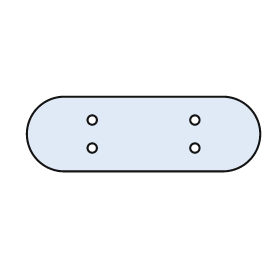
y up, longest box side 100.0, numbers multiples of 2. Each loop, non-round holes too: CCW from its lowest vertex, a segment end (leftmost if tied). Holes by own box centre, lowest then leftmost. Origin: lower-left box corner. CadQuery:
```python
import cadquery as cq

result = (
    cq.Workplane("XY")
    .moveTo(16.0, 0.0)
    .lineTo(84.0, 0.0)
    .threePointArc((100.0, 16.0), (84.0, 32.0))
    .lineTo(16.0, 32.0)
    .threePointArc((0.0, 16.0), (16.0, 0.0))
    .close()
    .moveTo(28.0, 10.0)
    .circle(2.0)
    .moveTo(72.0, 10.0)
    .circle(2.0)
    .moveTo(28.0, 22.0)
    .circle(2.0)
    .moveTo(72.0, 22.0)
    .circle(2.0)
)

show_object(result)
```